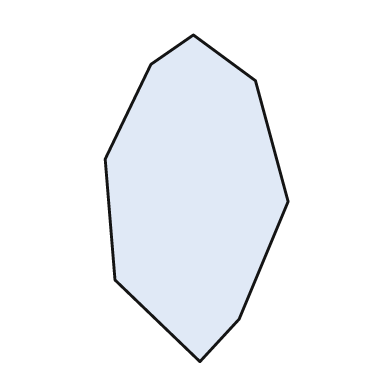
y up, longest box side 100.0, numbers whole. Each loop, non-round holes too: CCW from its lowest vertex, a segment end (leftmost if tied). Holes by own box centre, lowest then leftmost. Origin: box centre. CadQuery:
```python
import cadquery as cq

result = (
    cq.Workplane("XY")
    .moveTo(1.0, -50.0)
    .lineTo(13.0, -37.0)
    .lineTo(28.0, -1.0)
    .lineTo(18.0, 36.0)
    .lineTo(-1.0, 50.0)
    .lineTo(-14.0, 41.0)
    .lineTo(-28.0, 12.0)
    .lineTo(-25.0, -25.0)
    .close()
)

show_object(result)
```